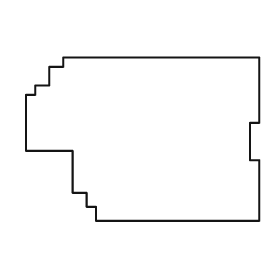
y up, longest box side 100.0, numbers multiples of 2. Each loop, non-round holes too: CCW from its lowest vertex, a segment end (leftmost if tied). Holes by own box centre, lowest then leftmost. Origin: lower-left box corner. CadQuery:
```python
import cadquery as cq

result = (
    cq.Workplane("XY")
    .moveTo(30.0, 0.0)
    .lineTo(100.0, 0.0)
    .lineTo(100.0, 26.0)
    .lineTo(96.0, 26.0)
    .lineTo(96.0, 42.0)
    .lineTo(100.0, 42.0)
    .lineTo(100.0, 70.0)
    .lineTo(16.0, 70.0)
    .lineTo(16.0, 66.0)
    .lineTo(10.0, 66.0)
    .lineTo(10.0, 58.0)
    .lineTo(4.0, 58.0)
    .lineTo(4.0, 54.0)
    .lineTo(0.0, 54.0)
    .lineTo(0.0, 30.0)
    .lineTo(20.0, 30.0)
    .lineTo(20.0, 12.0)
    .lineTo(26.0, 12.0)
    .lineTo(26.0, 6.0)
    .lineTo(30.0, 6.0)
    .close()
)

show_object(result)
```